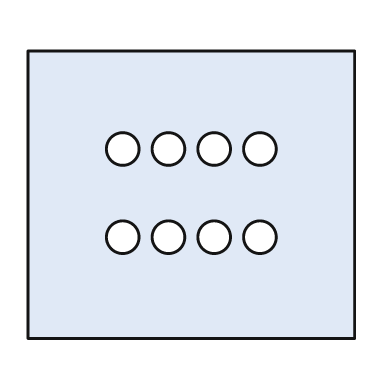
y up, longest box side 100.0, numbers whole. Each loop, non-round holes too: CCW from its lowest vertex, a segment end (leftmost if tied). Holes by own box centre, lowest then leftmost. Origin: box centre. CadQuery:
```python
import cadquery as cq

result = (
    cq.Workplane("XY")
    .moveTo(-50.0, -44.0)
    .lineTo(50.0, -44.0)
    .lineTo(50.0, 44.0)
    .lineTo(-50.0, 44.0)
    .close()
    .moveTo(-21.0, -13.0)
    .circle(5.0)
    .moveTo(-7.0, -13.0)
    .circle(5.0)
    .moveTo(7.0, -13.0)
    .circle(5.0)
    .moveTo(21.0, -13.0)
    .circle(5.0)
    .moveTo(-21.0, 14.0)
    .circle(5.0)
    .moveTo(-7.0, 14.0)
    .circle(5.0)
    .moveTo(7.0, 14.0)
    .circle(5.0)
    .moveTo(21.0, 14.0)
    .circle(5.0)
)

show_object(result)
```